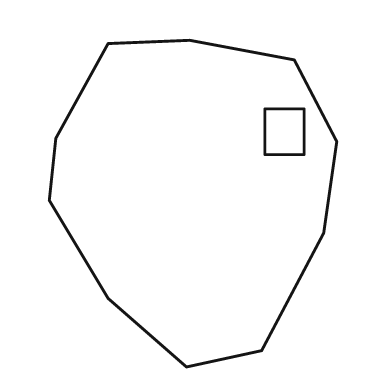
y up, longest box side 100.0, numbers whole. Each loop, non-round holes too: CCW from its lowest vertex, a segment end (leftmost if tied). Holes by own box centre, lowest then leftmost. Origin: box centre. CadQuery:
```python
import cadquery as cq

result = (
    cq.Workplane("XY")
    .moveTo(-2.0, -50.0)
    .lineTo(21.0, -45.0)
    .lineTo(40.0, -9.0)
    .lineTo(44.0, 19.0)
    .lineTo(31.0, 44.0)
    .lineTo(-1.0, 50.0)
    .lineTo(-26.0, 49.0)
    .lineTo(-42.0, 20.0)
    .lineTo(-44.0, 1.0)
    .lineTo(-26.0, -29.0)
    .close()
    .moveTo(22.0, 15.0)
    .lineTo(34.0, 15.0)
    .lineTo(34.0, 29.0)
    .lineTo(22.0, 29.0)
    .close()
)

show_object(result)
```